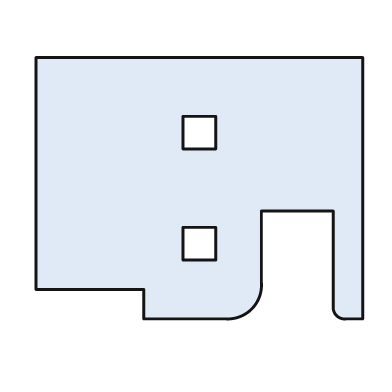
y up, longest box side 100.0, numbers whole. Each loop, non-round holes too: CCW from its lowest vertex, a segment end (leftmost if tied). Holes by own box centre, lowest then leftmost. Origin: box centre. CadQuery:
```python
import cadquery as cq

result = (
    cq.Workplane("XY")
    .moveTo(-17.0, -40.0)
    .lineTo(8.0, -40.0)
    .threePointArc((16.0, -37.0), (19.0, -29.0))
    .lineTo(19.0, -7.0)
    .lineTo(41.0, -7.0)
    .lineTo(41.0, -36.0)
    .threePointArc((42.0, -39.0), (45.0, -40.0))
    .lineTo(50.0, -40.0)
    .lineTo(50.0, 40.0)
    .lineTo(-50.0, 40.0)
    .lineTo(-50.0, -31.0)
    .lineTo(-17.0, -31.0)
    .close()
    .moveTo(-5.0, -22.0)
    .lineTo(5.0, -22.0)
    .lineTo(5.0, -12.0)
    .lineTo(-5.0, -12.0)
    .close()
    .moveTo(-5.0, 12.0)
    .lineTo(5.0, 12.0)
    .lineTo(5.0, 22.0)
    .lineTo(-5.0, 22.0)
    .close()
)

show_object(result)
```